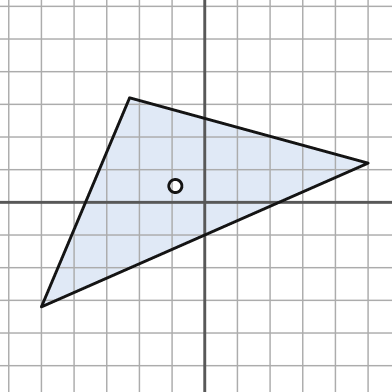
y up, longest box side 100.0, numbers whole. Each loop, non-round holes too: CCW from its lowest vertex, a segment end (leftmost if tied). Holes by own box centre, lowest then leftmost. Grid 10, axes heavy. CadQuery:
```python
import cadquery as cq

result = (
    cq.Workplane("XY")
    .moveTo(-50.0, -32.0)
    .lineTo(50.0, 12.0)
    .lineTo(-23.0, 32.0)
    .close()
    .moveTo(-9.0, 5.0)
    .circle(2.0)
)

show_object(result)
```